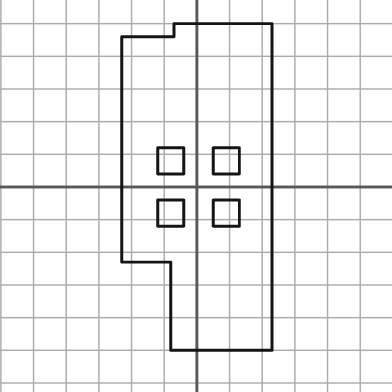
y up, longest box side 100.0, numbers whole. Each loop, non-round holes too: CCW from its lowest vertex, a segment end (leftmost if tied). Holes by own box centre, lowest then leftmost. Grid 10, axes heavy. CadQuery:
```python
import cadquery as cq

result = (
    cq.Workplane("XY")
    .moveTo(-8.0, -50.0)
    .lineTo(23.0, -50.0)
    .lineTo(23.0, 50.0)
    .lineTo(-7.0, 50.0)
    .lineTo(-7.0, 46.0)
    .lineTo(-23.0, 46.0)
    .lineTo(-23.0, -23.0)
    .lineTo(-8.0, -23.0)
    .close()
    .moveTo(-12.0, -12.0)
    .lineTo(-4.0, -12.0)
    .lineTo(-4.0, -4.0)
    .lineTo(-12.0, -4.0)
    .close()
    .moveTo(5.0, -12.0)
    .lineTo(13.0, -12.0)
    .lineTo(13.0, -4.0)
    .lineTo(5.0, -4.0)
    .close()
    .moveTo(-12.0, 4.0)
    .lineTo(-4.0, 4.0)
    .lineTo(-4.0, 12.0)
    .lineTo(-12.0, 12.0)
    .close()
    .moveTo(5.0, 4.0)
    .lineTo(13.0, 4.0)
    .lineTo(13.0, 12.0)
    .lineTo(5.0, 12.0)
    .close()
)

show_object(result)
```